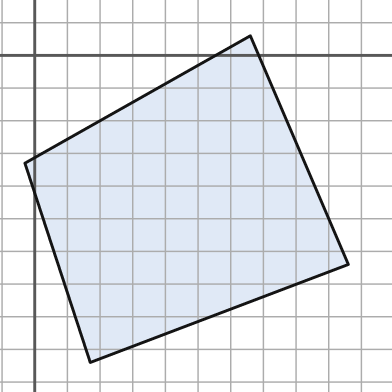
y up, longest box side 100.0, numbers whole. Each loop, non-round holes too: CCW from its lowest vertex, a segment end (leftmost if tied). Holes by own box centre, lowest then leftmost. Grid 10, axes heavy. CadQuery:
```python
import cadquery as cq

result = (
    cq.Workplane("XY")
    .moveTo(17.0, -94.0)
    .lineTo(96.0, -64.0)
    .lineTo(66.0, 6.0)
    .lineTo(-3.0, -33.0)
    .close()
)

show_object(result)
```